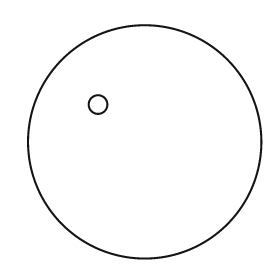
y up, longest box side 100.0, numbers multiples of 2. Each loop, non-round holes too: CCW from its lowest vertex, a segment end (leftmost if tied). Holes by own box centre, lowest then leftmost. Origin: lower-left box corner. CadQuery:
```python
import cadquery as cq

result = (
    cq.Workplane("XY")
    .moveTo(50.0, 50.0)
    .circle(50.0)
    .moveTo(30.0, 66.0)
    .circle(4.0)
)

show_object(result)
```